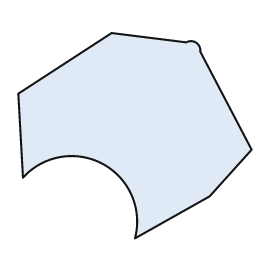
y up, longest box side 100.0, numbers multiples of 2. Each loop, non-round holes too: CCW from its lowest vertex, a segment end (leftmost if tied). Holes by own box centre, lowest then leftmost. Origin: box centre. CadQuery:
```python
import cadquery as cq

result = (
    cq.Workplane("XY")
    .moveTo(0.0, -44.0)
    .lineTo(32.0, -26.0)
    .lineTo(50.0, -6.0)
    .lineTo(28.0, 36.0)
    .threePointArc((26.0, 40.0), (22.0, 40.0))
    .lineTo(-10.0, 44.0)
    .lineTo(-50.0, 18.0)
    .lineTo(-48.0, -18.0)
    .threePointArc((-14.0, -12.0), (0.0, -44.0))
    .close()
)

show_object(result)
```